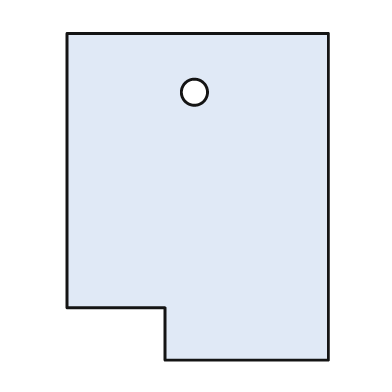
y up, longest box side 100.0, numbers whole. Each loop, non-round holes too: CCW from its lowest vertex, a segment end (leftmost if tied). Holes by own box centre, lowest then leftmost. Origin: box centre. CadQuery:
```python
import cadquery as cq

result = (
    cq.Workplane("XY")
    .moveTo(-10.0, -50.0)
    .lineTo(40.0, -50.0)
    .lineTo(40.0, 50.0)
    .lineTo(-40.0, 50.0)
    .lineTo(-40.0, -34.0)
    .lineTo(-10.0, -34.0)
    .close()
    .moveTo(-1.0, 32.0)
    .circle(4.0)
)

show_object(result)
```